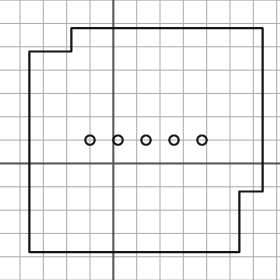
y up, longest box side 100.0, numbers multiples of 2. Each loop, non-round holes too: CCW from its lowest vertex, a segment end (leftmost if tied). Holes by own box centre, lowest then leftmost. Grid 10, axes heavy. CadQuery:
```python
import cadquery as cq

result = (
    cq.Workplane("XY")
    .moveTo(-36.0, -38.0)
    .lineTo(54.0, -38.0)
    .lineTo(54.0, -12.0)
    .lineTo(64.0, -12.0)
    .lineTo(64.0, 58.0)
    .lineTo(-18.0, 58.0)
    .lineTo(-18.0, 48.0)
    .lineTo(-36.0, 48.0)
    .close()
    .moveTo(-10.0, 10.0)
    .circle(2.0)
    .moveTo(2.0, 10.0)
    .circle(2.0)
    .moveTo(14.0, 10.0)
    .circle(2.0)
    .moveTo(26.0, 10.0)
    .circle(2.0)
    .moveTo(38.0, 10.0)
    .circle(2.0)
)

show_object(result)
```